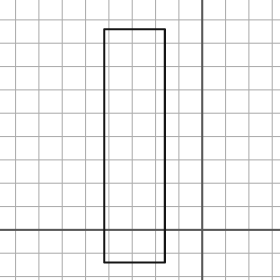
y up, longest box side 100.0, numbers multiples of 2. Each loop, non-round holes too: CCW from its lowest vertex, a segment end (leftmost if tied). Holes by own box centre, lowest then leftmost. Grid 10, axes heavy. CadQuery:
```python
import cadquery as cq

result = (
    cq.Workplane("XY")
    .moveTo(-42.0, -14.0)
    .lineTo(-16.0, -14.0)
    .lineTo(-16.0, 86.0)
    .lineTo(-42.0, 86.0)
    .close()
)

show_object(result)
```